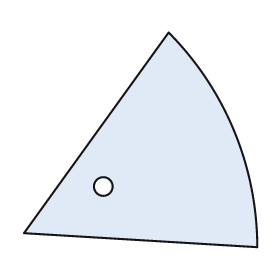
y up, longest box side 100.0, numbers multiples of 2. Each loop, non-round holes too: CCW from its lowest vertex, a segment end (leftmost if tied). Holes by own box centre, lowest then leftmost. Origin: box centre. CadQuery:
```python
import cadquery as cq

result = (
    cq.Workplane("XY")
    .moveTo(50.0, -46.0)
    .threePointArc((40.0, 4.0), (12.0, 46.0))
    .lineTo(-50.0, -40.0)
    .close()
    .moveTo(-16.0, -20.0)
    .circle(4.0)
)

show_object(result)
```